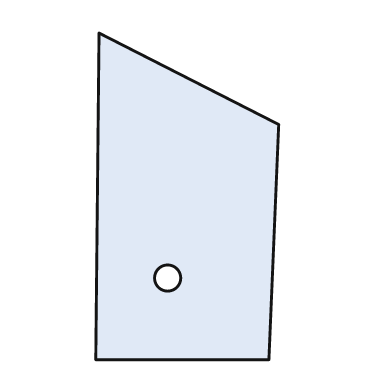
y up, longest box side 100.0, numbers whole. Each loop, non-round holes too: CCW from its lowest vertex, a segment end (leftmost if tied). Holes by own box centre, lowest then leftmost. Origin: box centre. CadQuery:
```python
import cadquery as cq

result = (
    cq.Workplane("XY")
    .moveTo(-28.0, -50.0)
    .lineTo(25.0, -50.0)
    .lineTo(28.0, 22.0)
    .lineTo(-27.0, 50.0)
    .close()
    .moveTo(-6.0, -25.0)
    .circle(4.0)
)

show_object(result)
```